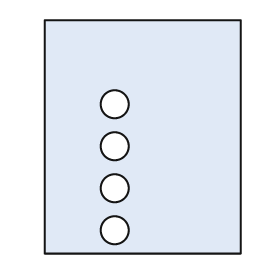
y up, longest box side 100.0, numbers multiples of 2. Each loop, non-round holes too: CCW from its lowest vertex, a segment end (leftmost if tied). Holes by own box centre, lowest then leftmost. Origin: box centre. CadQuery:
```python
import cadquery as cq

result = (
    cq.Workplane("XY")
    .moveTo(-42.0, -50.0)
    .lineTo(42.0, -50.0)
    .lineTo(42.0, 50.0)
    .lineTo(-42.0, 50.0)
    .close()
    .moveTo(-12.0, -40.0)
    .circle(6.0)
    .moveTo(-12.0, -22.0)
    .circle(6.0)
    .moveTo(-12.0, -4.0)
    .circle(6.0)
    .moveTo(-12.0, 14.0)
    .circle(6.0)
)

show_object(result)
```